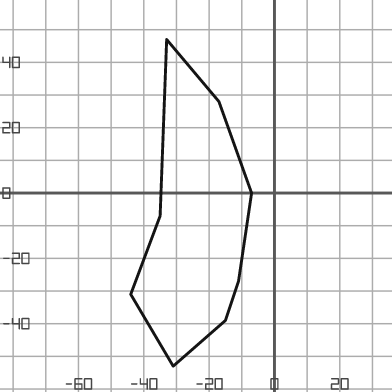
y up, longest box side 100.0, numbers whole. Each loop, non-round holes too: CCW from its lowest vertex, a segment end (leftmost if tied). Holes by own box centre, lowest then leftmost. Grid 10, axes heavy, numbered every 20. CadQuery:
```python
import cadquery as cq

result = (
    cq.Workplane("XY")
    .moveTo(-31.0, -53.0)
    .lineTo(-15.0, -39.0)
    .lineTo(-11.0, -27.0)
    .lineTo(-7.0, 0.0)
    .lineTo(-17.0, 28.0)
    .lineTo(-33.0, 47.0)
    .lineTo(-35.0, -7.0)
    .lineTo(-44.0, -31.0)
    .close()
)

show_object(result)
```